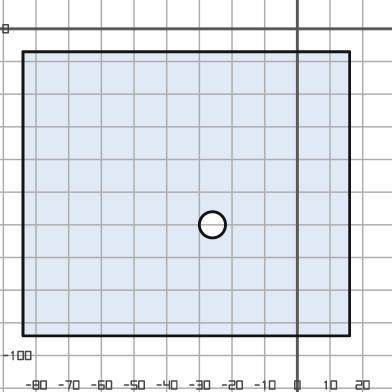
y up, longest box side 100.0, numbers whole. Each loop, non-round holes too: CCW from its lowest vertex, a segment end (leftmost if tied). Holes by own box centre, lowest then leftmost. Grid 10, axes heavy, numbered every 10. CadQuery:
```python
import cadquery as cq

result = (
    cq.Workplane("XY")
    .moveTo(-84.0, -94.0)
    .lineTo(16.0, -94.0)
    .lineTo(16.0, -7.0)
    .lineTo(-84.0, -7.0)
    .close()
    .moveTo(-26.0, -60.0)
    .circle(4.0)
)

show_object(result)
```